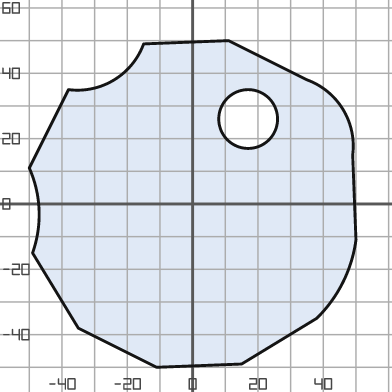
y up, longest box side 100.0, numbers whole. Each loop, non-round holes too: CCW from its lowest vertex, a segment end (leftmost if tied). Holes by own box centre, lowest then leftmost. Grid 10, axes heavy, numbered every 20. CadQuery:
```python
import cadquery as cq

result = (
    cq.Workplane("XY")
    .moveTo(-11.0, -50.0)
    .lineTo(15.0, -49.0)
    .lineTo(38.0, -35.0)
    .threePointArc((46.0, -24.0), (50.0, -11.0))
    .lineTo(49.0, 15.0)
    .threePointArc((46.0, 29.0), (35.0, 38.0))
    .lineTo(11.0, 50.0)
    .lineTo(-15.0, 49.0)
    .threePointArc((-24.0, 38.0), (-38.0, 35.0))
    .lineTo(-50.0, 11.0)
    .threePointArc((-47.0, -2.0), (-49.0, -15.0))
    .lineTo(-35.0, -38.0)
    .close()
    .moveTo(17.0, 26.0)
    .circle(9.0)
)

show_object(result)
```